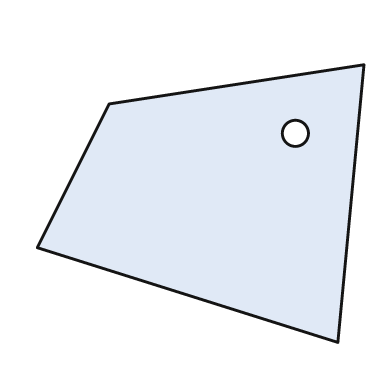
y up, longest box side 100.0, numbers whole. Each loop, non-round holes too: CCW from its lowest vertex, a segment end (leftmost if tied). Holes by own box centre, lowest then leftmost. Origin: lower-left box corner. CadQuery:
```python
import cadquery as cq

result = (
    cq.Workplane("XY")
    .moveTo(92.0, 0.0)
    .lineTo(100.0, 85.0)
    .lineTo(22.0, 73.0)
    .lineTo(0.0, 29.0)
    .close()
    .moveTo(79.0, 64.0)
    .circle(4.0)
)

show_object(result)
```